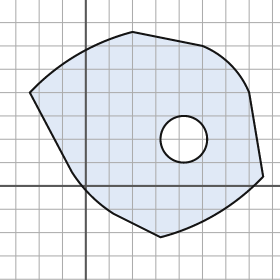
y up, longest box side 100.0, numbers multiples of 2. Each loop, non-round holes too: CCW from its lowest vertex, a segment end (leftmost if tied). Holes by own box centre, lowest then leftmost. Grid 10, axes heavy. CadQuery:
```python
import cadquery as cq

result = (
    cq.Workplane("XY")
    .moveTo(32.0, -22.0)
    .threePointArc((56.0, -12.0), (76.0, 4.0))
    .lineTo(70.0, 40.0)
    .threePointArc((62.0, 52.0), (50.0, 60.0))
    .lineTo(20.0, 66.0)
    .threePointArc((-4.0, 56.0), (-24.0, 40.0))
    .lineTo(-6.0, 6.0)
    .threePointArc((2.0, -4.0), (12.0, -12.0))
    .close()
    .moveTo(42.0, 20.0)
    .circle(10.0)
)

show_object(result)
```